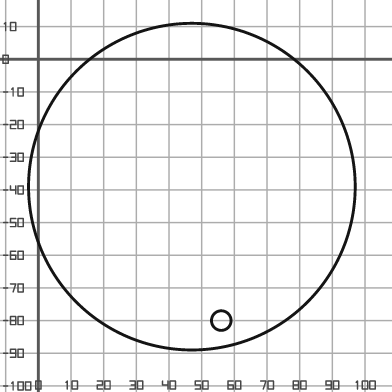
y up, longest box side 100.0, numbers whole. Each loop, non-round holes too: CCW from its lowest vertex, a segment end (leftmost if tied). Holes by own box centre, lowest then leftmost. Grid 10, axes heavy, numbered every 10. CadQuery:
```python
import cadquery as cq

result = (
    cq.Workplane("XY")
    .moveTo(47.0, -39.0)
    .circle(50.0)
    .moveTo(56.0, -80.0)
    .circle(3.0)
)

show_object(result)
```